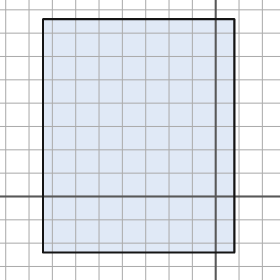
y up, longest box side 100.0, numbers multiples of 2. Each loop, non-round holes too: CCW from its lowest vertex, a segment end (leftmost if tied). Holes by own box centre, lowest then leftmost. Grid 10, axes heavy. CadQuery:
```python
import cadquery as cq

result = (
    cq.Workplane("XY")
    .moveTo(-74.0, -24.0)
    .lineTo(8.0, -24.0)
    .lineTo(8.0, 76.0)
    .lineTo(-74.0, 76.0)
    .close()
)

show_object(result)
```